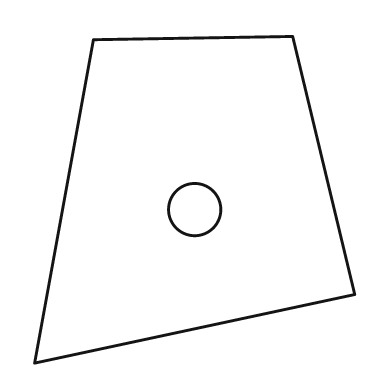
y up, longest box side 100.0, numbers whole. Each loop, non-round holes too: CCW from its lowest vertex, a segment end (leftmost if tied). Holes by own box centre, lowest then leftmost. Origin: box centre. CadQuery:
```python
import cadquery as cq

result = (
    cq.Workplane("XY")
    .moveTo(-49.0, -50.0)
    .lineTo(49.0, -29.0)
    .lineTo(30.0, 50.0)
    .lineTo(-31.0, 49.0)
    .close()
    .moveTo(0.0, -3.0)
    .circle(8.0)
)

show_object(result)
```